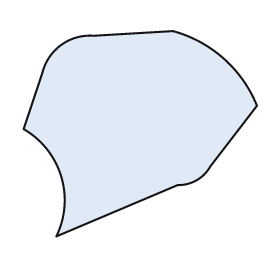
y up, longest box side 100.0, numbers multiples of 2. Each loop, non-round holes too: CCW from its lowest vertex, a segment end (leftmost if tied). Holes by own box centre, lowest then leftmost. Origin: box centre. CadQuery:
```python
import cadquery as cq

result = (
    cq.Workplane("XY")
    .moveTo(-36.0, -44.0)
    .lineTo(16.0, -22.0)
    .threePointArc((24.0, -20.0), (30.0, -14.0))
    .lineTo(50.0, 12.0)
    .threePointArc((36.0, 32.0), (14.0, 44.0))
    .lineTo(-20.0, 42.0)
    .threePointArc((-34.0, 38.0), (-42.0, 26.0))
    .lineTo(-50.0, 2.0)
    .threePointArc((-34.0, -18.0), (-36.0, -44.0))
    .close()
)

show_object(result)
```